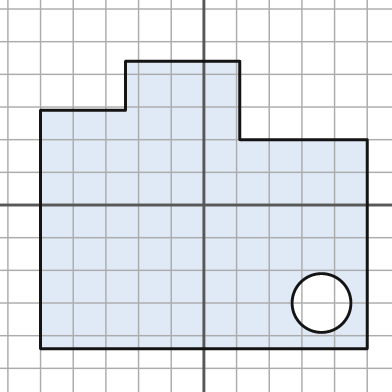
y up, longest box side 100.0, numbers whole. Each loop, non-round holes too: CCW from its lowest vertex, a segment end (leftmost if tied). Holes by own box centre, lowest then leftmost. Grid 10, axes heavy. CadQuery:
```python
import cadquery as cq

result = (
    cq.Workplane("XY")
    .moveTo(-50.0, -44.0)
    .lineTo(50.0, -44.0)
    .lineTo(50.0, 20.0)
    .lineTo(11.0, 20.0)
    .lineTo(11.0, 44.0)
    .lineTo(-24.0, 44.0)
    .lineTo(-24.0, 29.0)
    .lineTo(-50.0, 29.0)
    .close()
    .moveTo(36.0, -30.0)
    .circle(9.0)
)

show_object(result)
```